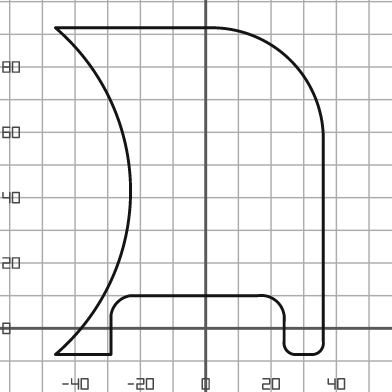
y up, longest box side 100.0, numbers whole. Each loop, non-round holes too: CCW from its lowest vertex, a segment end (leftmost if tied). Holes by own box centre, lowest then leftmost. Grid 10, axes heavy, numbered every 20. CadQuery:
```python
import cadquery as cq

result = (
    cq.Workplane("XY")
    .moveTo(-46.0, -8.0)
    .lineTo(-29.0, -8.0)
    .lineTo(-29.0, 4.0)
    .threePointArc((-27.0, 8.0), (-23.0, 10.0))
    .lineTo(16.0, 10.0)
    .threePointArc((22.0, 8.0), (24.0, 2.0))
    .lineTo(24.0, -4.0)
    .threePointArc((25.0, -7.0), (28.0, -8.0))
    .lineTo(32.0, -8.0)
    .threePointArc((35.0, -7.0), (36.0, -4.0))
    .lineTo(36.0, 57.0)
    .threePointArc((26.0, 82.0), (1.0, 92.0))
    .lineTo(-46.0, 92.0)
    .threePointArc((-23.0, 42.0), (-46.0, -8.0))
    .close()
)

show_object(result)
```